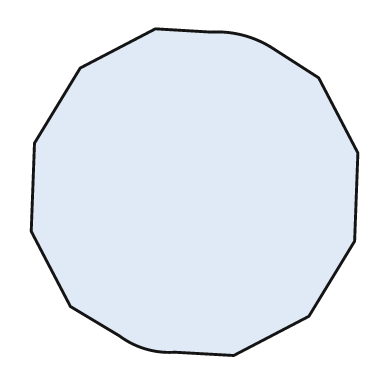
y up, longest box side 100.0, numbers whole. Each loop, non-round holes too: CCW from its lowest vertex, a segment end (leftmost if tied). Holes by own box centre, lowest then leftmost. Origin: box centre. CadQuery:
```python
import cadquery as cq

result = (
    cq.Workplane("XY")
    .moveTo(12.0, -50.0)
    .lineTo(35.0, -38.0)
    .lineTo(49.0, -15.0)
    .lineTo(50.0, 12.0)
    .lineTo(38.0, 35.0)
    .lineTo(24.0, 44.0)
    .threePointArc((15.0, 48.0), (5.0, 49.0))
    .lineTo(-12.0, 50.0)
    .lineTo(-35.0, 38.0)
    .lineTo(-49.0, 15.0)
    .lineTo(-50.0, -12.0)
    .lineTo(-38.0, -35.0)
    .lineTo(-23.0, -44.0)
    .threePointArc((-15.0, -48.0), (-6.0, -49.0))
    .close()
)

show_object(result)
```